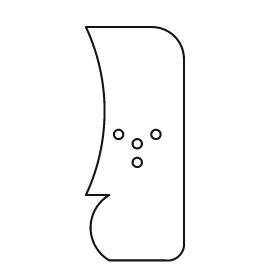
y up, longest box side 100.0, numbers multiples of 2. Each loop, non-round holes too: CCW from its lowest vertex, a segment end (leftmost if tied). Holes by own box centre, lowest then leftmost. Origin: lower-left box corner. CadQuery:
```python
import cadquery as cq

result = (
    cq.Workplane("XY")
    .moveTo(10.0, 0.0)
    .lineTo(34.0, 0.0)
    .threePointArc((40.0, 2.0), (42.0, 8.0))
    .lineTo(42.0, 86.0)
    .threePointArc((38.0, 96.0), (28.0, 100.0))
    .lineTo(0.0, 100.0)
    .threePointArc((8.0, 64.0), (0.0, 28.0))
    .lineTo(10.0, 28.0)
    .threePointArc((2.0, 14.0), (10.0, 0.0))
    .close()
    .moveTo(22.0, 42.0)
    .circle(2.0)
    .moveTo(22.0, 50.0)
    .circle(2.0)
    .moveTo(14.0, 54.0)
    .circle(2.0)
    .moveTo(30.0, 54.0)
    .circle(2.0)
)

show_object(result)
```